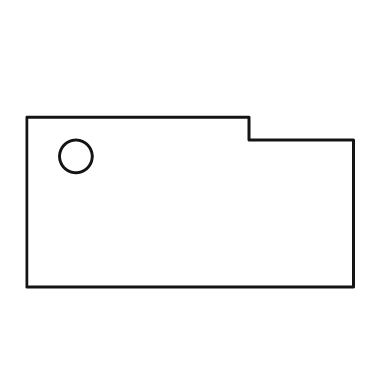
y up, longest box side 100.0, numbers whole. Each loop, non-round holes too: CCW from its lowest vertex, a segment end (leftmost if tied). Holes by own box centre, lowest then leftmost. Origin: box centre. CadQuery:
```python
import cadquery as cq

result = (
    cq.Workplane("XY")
    .moveTo(-50.0, -26.0)
    .lineTo(50.0, -26.0)
    .lineTo(50.0, 19.0)
    .lineTo(18.0, 19.0)
    .lineTo(18.0, 26.0)
    .lineTo(-50.0, 26.0)
    .close()
    .moveTo(-35.0, 14.0)
    .circle(5.0)
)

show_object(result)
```